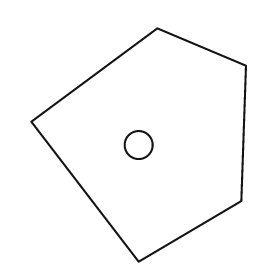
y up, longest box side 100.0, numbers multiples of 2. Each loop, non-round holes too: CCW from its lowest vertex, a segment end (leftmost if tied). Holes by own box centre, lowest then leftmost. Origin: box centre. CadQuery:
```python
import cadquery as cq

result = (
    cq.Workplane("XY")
    .moveTo(0.0, -50.0)
    .lineTo(44.0, -24.0)
    .lineTo(46.0, 34.0)
    .lineTo(8.0, 50.0)
    .lineTo(-46.0, 10.0)
    .close()
    .moveTo(0.0, 0.0)
    .circle(6.0)
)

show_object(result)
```